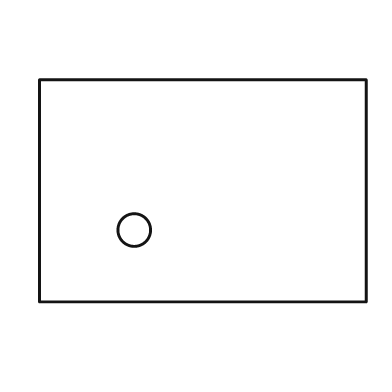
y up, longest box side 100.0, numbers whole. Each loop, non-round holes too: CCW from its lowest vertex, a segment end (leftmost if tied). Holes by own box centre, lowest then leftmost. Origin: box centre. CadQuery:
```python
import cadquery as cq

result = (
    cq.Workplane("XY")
    .moveTo(-50.0, -34.0)
    .lineTo(50.0, -34.0)
    .lineTo(50.0, 34.0)
    .lineTo(-50.0, 34.0)
    .close()
    .moveTo(-21.0, -12.0)
    .circle(5.0)
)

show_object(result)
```